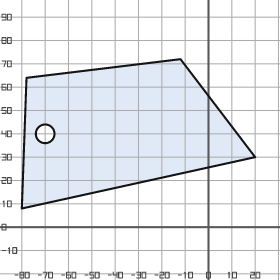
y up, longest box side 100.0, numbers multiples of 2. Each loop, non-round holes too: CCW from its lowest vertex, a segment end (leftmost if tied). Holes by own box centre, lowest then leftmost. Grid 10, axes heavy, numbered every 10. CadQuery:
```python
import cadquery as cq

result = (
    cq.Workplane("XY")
    .moveTo(-80.0, 8.0)
    .lineTo(20.0, 30.0)
    .lineTo(-12.0, 72.0)
    .lineTo(-78.0, 64.0)
    .close()
    .moveTo(-70.0, 40.0)
    .circle(4.0)
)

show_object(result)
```